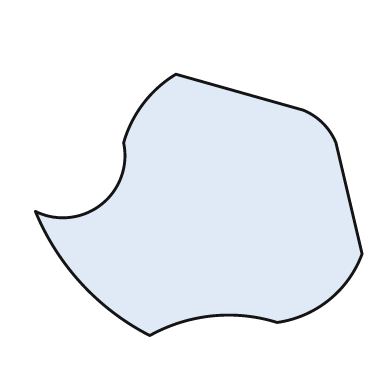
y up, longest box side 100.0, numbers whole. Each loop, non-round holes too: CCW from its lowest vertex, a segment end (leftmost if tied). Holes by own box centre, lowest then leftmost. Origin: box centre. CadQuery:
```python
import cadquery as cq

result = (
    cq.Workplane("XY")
    .moveTo(-15.0, -40.0)
    .threePointArc((4.0, -34.0), (24.0, -36.0))
    .threePointArc((40.0, -29.0), (50.0, -15.0))
    .lineTo(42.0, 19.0)
    .threePointArc((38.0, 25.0), (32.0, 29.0))
    .lineTo(-7.0, 40.0)
    .threePointArc((-17.0, 31.0), (-23.0, 19.0))
    .threePointArc((-30.0, 0.0), (-50.0, -2.0))
    .threePointArc((-36.0, -24.0), (-15.0, -40.0))
    .close()
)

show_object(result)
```